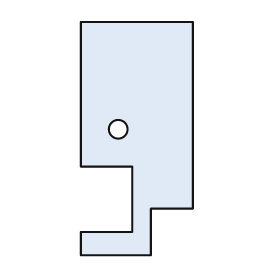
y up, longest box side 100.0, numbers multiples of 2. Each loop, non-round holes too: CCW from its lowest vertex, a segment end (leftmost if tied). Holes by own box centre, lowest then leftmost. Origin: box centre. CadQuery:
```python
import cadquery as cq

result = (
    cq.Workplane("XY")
    .moveTo(-24.0, -50.0)
    .lineTo(6.0, -50.0)
    .lineTo(6.0, -30.0)
    .lineTo(24.0, -30.0)
    .lineTo(24.0, 50.0)
    .lineTo(-24.0, 50.0)
    .lineTo(-24.0, -12.0)
    .lineTo(-2.0, -12.0)
    .lineTo(-2.0, -40.0)
    .lineTo(-24.0, -40.0)
    .close()
    .moveTo(-8.0, 4.0)
    .circle(4.0)
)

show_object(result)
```